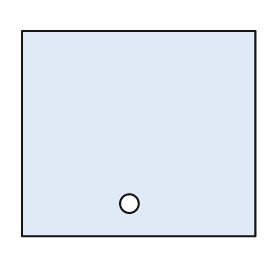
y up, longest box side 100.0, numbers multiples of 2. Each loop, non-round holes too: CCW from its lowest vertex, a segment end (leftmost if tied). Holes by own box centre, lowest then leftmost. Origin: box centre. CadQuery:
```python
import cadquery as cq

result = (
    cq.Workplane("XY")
    .moveTo(-50.0, -44.0)
    .lineTo(50.0, -44.0)
    .lineTo(50.0, 44.0)
    .lineTo(-50.0, 44.0)
    .close()
    .moveTo(-4.0, -30.0)
    .circle(4.0)
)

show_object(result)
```